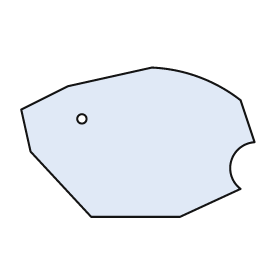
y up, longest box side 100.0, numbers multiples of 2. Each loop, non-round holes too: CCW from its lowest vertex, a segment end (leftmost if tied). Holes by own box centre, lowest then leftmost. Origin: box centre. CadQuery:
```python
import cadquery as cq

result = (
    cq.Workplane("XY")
    .moveTo(-20.0, -32.0)
    .lineTo(18.0, -32.0)
    .lineTo(44.0, -20.0)
    .threePointArc((40.0, -8.0), (50.0, 0.0))
    .lineTo(44.0, 18.0)
    .threePointArc((26.0, 28.0), (6.0, 32.0))
    .lineTo(-30.0, 24.0)
    .lineTo(-50.0, 14.0)
    .lineTo(-46.0, -4.0)
    .close()
    .moveTo(-24.0, 10.0)
    .circle(2.0)
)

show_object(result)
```